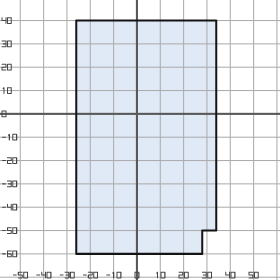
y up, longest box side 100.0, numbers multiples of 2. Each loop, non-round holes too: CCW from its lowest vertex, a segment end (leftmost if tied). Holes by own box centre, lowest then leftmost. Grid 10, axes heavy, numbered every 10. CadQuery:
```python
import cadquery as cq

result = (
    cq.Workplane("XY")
    .moveTo(-26.0, -60.0)
    .lineTo(28.0, -60.0)
    .lineTo(28.0, -50.0)
    .lineTo(34.0, -50.0)
    .lineTo(34.0, 40.0)
    .lineTo(-26.0, 40.0)
    .close()
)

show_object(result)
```